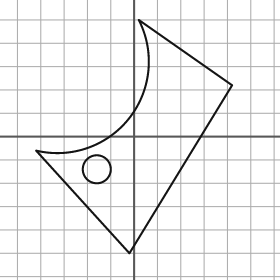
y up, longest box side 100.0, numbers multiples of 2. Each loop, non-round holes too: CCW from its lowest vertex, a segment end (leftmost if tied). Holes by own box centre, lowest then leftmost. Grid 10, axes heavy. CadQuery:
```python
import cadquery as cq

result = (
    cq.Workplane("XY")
    .moveTo(-2.0, -50.0)
    .lineTo(42.0, 22.0)
    .lineTo(2.0, 50.0)
    .threePointArc((-2.0, 8.0), (-42.0, -6.0))
    .close()
    .moveTo(-16.0, -14.0)
    .circle(6.0)
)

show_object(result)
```